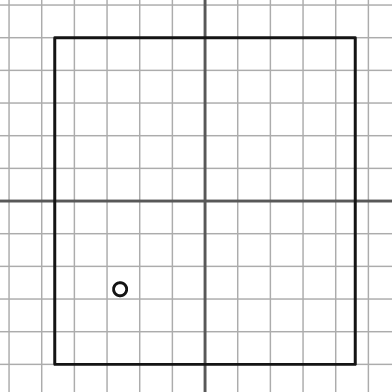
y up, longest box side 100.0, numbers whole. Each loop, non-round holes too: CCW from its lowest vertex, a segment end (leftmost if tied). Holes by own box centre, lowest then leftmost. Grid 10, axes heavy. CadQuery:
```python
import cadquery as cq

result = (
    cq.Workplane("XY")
    .moveTo(-46.0, -50.0)
    .lineTo(46.0, -50.0)
    .lineTo(46.0, 50.0)
    .lineTo(-46.0, 50.0)
    .close()
    .moveTo(-26.0, -27.0)
    .circle(2.0)
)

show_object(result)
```